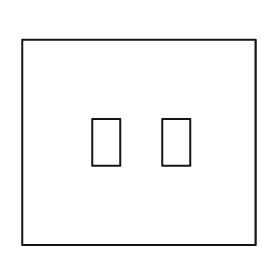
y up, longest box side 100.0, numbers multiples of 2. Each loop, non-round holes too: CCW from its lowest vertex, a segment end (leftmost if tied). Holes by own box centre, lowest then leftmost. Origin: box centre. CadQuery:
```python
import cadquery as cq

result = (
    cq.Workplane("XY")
    .moveTo(-50.0, -44.0)
    .lineTo(50.0, -44.0)
    .lineTo(50.0, 44.0)
    .lineTo(-50.0, 44.0)
    .close()
    .moveTo(-20.0, -10.0)
    .lineTo(-8.0, -10.0)
    .lineTo(-8.0, 10.0)
    .lineTo(-20.0, 10.0)
    .close()
    .moveTo(10.0, -10.0)
    .lineTo(22.0, -10.0)
    .lineTo(22.0, 10.0)
    .lineTo(10.0, 10.0)
    .close()
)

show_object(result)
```